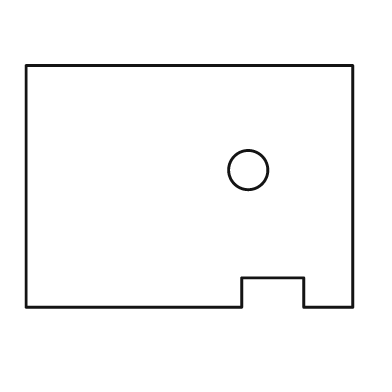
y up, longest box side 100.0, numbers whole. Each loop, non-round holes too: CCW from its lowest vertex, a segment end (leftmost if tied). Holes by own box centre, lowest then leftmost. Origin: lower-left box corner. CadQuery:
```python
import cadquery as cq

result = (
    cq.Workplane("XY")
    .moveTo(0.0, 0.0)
    .lineTo(66.0, 0.0)
    .lineTo(66.0, 9.0)
    .lineTo(85.0, 9.0)
    .lineTo(85.0, 0.0)
    .lineTo(100.0, 0.0)
    .lineTo(100.0, 74.0)
    .lineTo(0.0, 74.0)
    .close()
    .moveTo(68.0, 42.0)
    .circle(6.0)
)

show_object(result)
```